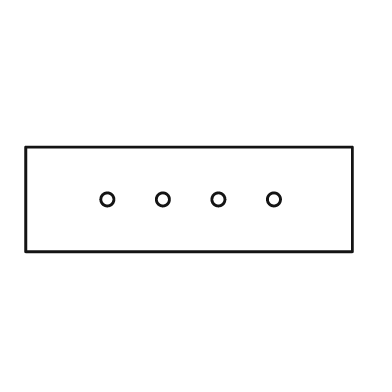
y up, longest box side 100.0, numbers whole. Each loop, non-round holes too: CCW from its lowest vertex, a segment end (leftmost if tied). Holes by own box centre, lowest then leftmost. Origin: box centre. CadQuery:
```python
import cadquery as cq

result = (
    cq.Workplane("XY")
    .moveTo(-50.0, -16.0)
    .lineTo(50.0, -16.0)
    .lineTo(50.0, 16.0)
    .lineTo(-50.0, 16.0)
    .close()
    .moveTo(-25.0, 0.0)
    .circle(2.0)
    .moveTo(-8.0, 0.0)
    .circle(2.0)
    .moveTo(9.0, 0.0)
    .circle(2.0)
    .moveTo(26.0, 0.0)
    .circle(2.0)
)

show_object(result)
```